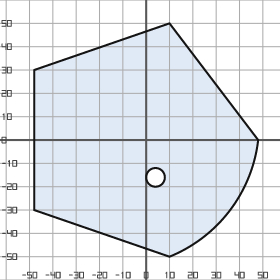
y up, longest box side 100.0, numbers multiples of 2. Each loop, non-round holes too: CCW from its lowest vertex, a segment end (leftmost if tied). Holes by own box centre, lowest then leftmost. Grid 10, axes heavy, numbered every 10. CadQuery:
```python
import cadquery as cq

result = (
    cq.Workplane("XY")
    .moveTo(10.0, -50.0)
    .threePointArc((36.0, -30.0), (48.0, 0.0))
    .lineTo(10.0, 50.0)
    .lineTo(-48.0, 30.0)
    .lineTo(-48.0, -30.0)
    .close()
    .moveTo(4.0, -16.0)
    .circle(4.0)
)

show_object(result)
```